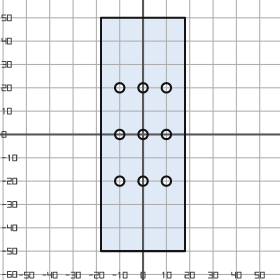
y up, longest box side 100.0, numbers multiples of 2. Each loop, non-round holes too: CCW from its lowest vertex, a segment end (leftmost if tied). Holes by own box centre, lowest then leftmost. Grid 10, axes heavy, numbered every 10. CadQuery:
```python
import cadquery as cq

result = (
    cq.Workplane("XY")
    .moveTo(-18.0, -50.0)
    .lineTo(18.0, -50.0)
    .lineTo(18.0, 50.0)
    .lineTo(-18.0, 50.0)
    .close()
    .moveTo(-10.0, -20.0)
    .circle(2.0)
    .moveTo(0.0, -20.0)
    .circle(2.0)
    .moveTo(10.0, -20.0)
    .circle(2.0)
    .moveTo(-10.0, 0.0)
    .circle(2.0)
    .moveTo(0.0, 0.0)
    .circle(2.0)
    .moveTo(10.0, 0.0)
    .circle(2.0)
    .moveTo(-10.0, 20.0)
    .circle(2.0)
    .moveTo(0.0, 20.0)
    .circle(2.0)
    .moveTo(10.0, 20.0)
    .circle(2.0)
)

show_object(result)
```